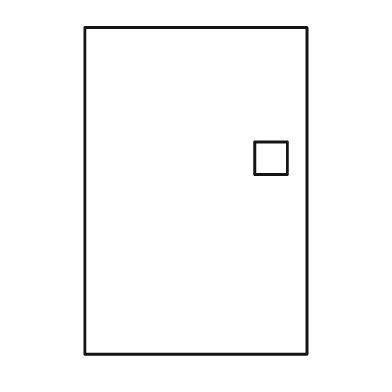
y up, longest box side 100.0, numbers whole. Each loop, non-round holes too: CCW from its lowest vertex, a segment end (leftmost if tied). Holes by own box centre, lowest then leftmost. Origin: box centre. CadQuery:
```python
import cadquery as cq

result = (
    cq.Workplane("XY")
    .moveTo(-34.0, -50.0)
    .lineTo(34.0, -50.0)
    .lineTo(34.0, 50.0)
    .lineTo(-34.0, 50.0)
    .close()
    .moveTo(18.0, 5.0)
    .lineTo(28.0, 5.0)
    .lineTo(28.0, 15.0)
    .lineTo(18.0, 15.0)
    .close()
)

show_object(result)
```